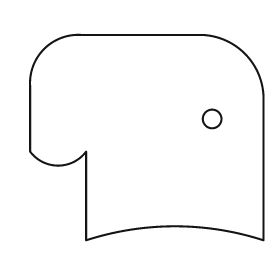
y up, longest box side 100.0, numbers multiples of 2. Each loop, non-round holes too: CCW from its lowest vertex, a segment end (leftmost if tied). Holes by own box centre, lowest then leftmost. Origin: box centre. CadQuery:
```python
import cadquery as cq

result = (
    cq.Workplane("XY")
    .moveTo(-26.0, -44.0)
    .threePointArc((12.0, -38.0), (50.0, -44.0))
    .lineTo(50.0, 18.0)
    .threePointArc((42.0, 36.0), (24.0, 44.0))
    .lineTo(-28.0, 44.0)
    .threePointArc((-44.0, 38.0), (-50.0, 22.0))
    .lineTo(-50.0, -6.0)
    .threePointArc((-38.0, -12.0), (-26.0, -6.0))
    .close()
    .moveTo(28.0, 8.0)
    .circle(4.0)
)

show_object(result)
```